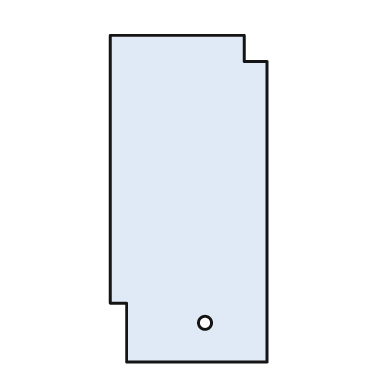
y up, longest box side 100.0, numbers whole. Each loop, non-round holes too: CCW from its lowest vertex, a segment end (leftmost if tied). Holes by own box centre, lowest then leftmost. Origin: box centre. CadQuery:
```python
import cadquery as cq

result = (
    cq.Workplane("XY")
    .moveTo(-19.0, -50.0)
    .lineTo(24.0, -50.0)
    .lineTo(24.0, 42.0)
    .lineTo(17.0, 42.0)
    .lineTo(17.0, 50.0)
    .lineTo(-24.0, 50.0)
    .lineTo(-24.0, -32.0)
    .lineTo(-19.0, -32.0)
    .close()
    .moveTo(5.0, -38.0)
    .circle(2.0)
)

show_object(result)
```